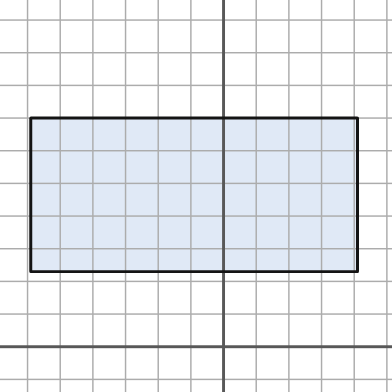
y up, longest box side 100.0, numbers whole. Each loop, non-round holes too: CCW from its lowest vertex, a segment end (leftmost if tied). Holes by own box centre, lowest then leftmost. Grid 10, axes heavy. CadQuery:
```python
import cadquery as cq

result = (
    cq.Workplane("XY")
    .moveTo(-59.0, 23.0)
    .lineTo(41.0, 23.0)
    .lineTo(41.0, 70.0)
    .lineTo(-59.0, 70.0)
    .close()
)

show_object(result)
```